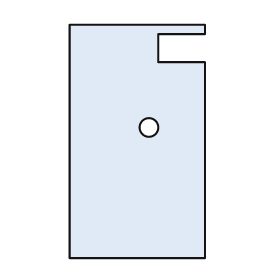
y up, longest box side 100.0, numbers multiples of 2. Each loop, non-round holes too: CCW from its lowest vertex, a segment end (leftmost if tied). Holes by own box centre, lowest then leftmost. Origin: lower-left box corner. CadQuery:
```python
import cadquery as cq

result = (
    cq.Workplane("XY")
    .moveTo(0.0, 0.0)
    .lineTo(58.0, 0.0)
    .lineTo(58.0, 84.0)
    .lineTo(38.0, 84.0)
    .lineTo(38.0, 96.0)
    .lineTo(58.0, 96.0)
    .lineTo(58.0, 100.0)
    .lineTo(0.0, 100.0)
    .close()
    .moveTo(34.0, 56.0)
    .circle(4.0)
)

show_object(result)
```